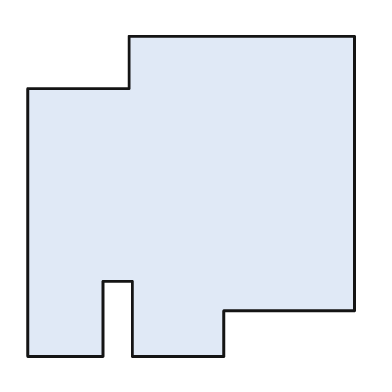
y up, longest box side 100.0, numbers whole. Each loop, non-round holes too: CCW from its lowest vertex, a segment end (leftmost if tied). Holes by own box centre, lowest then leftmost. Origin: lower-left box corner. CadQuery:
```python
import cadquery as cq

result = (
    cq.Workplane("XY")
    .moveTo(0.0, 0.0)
    .lineTo(23.0, 0.0)
    .lineTo(23.0, 23.0)
    .lineTo(32.0, 23.0)
    .lineTo(32.0, 0.0)
    .lineTo(60.0, 0.0)
    .lineTo(60.0, 14.0)
    .lineTo(100.0, 14.0)
    .lineTo(100.0, 98.0)
    .lineTo(31.0, 98.0)
    .lineTo(31.0, 82.0)
    .lineTo(0.0, 82.0)
    .close()
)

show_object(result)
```